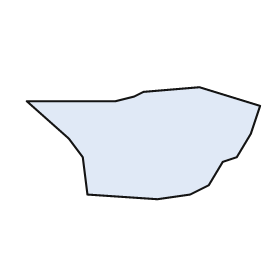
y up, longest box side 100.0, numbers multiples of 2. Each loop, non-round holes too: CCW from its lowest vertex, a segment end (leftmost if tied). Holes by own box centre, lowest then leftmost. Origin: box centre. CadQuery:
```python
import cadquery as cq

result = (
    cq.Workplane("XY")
    .moveTo(6.0, -24.0)
    .lineTo(20.0, -22.0)
    .lineTo(28.0, -18.0)
    .lineTo(34.0, -8.0)
    .lineTo(40.0, -6.0)
    .lineTo(46.0, 4.0)
    .lineTo(50.0, 16.0)
    .lineTo(24.0, 24.0)
    .lineTo(0.0, 22.0)
    .lineTo(-4.0, 20.0)
    .lineTo(-12.0, 18.0)
    .lineTo(-50.0, 18.0)
    .lineTo(-32.0, 2.0)
    .lineTo(-26.0, -6.0)
    .lineTo(-24.0, -22.0)
    .close()
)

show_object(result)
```